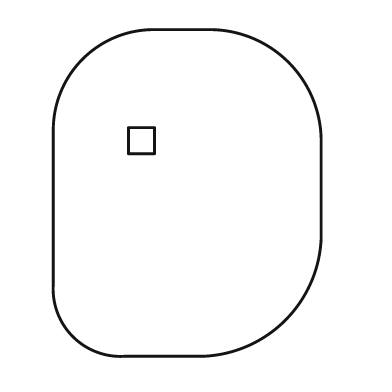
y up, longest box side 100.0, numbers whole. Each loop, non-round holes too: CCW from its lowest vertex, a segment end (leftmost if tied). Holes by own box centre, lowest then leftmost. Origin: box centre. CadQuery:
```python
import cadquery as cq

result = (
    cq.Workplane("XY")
    .moveTo(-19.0, -50.0)
    .lineTo(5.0, -50.0)
    .threePointArc((30.0, -39.0), (41.0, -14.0))
    .lineTo(41.0, 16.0)
    .threePointArc((31.0, 40.0), (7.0, 50.0))
    .lineTo(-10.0, 50.0)
    .threePointArc((-32.0, 41.0), (-41.0, 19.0))
    .lineTo(-41.0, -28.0)
    .threePointArc((-35.0, -44.0), (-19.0, -50.0))
    .close()
    .moveTo(-18.0, 12.0)
    .lineTo(-10.0, 12.0)
    .lineTo(-10.0, 20.0)
    .lineTo(-18.0, 20.0)
    .close()
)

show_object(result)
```